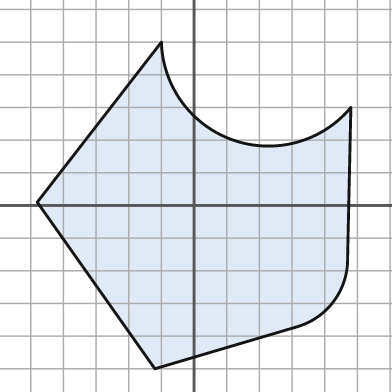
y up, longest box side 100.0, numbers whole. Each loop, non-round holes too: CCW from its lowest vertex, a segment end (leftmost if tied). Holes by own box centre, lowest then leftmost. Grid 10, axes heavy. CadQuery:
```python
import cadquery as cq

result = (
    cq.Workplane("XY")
    .moveTo(-12.0, -50.0)
    .lineTo(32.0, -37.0)
    .threePointArc((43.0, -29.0), (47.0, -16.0))
    .lineTo(48.0, 30.0)
    .threePointArc((12.0, 20.0), (-10.0, 50.0))
    .lineTo(-48.0, 1.0)
    .close()
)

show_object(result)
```